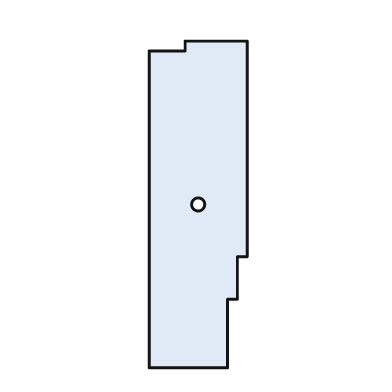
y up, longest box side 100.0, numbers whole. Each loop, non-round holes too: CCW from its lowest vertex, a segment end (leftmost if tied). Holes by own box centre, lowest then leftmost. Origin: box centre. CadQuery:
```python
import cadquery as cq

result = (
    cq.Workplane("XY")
    .moveTo(-15.0, -50.0)
    .lineTo(9.0, -50.0)
    .lineTo(9.0, -29.0)
    .lineTo(12.0, -29.0)
    .lineTo(12.0, -16.0)
    .lineTo(15.0, -16.0)
    .lineTo(15.0, 50.0)
    .lineTo(-4.0, 50.0)
    .lineTo(-4.0, 47.0)
    .lineTo(-15.0, 47.0)
    .close()
    .moveTo(0.0, 0.0)
    .circle(2.0)
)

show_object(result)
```